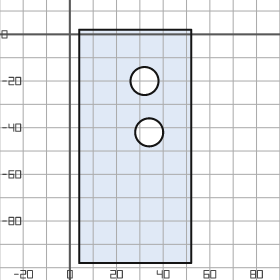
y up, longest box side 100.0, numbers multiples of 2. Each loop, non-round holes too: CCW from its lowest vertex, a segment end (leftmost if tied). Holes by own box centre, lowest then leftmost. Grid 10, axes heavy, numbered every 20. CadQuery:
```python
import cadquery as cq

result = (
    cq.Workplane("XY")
    .moveTo(4.0, -98.0)
    .lineTo(52.0, -98.0)
    .lineTo(52.0, 2.0)
    .lineTo(4.0, 2.0)
    .close()
    .moveTo(34.0, -42.0)
    .circle(6.0)
    .moveTo(32.0, -20.0)
    .circle(6.0)
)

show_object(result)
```